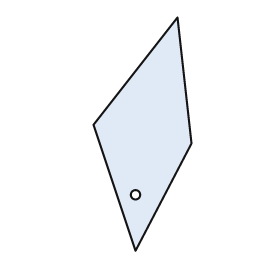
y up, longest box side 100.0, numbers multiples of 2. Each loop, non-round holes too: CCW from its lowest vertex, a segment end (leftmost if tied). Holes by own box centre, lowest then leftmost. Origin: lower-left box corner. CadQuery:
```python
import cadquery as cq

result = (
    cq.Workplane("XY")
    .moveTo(18.0, 0.0)
    .lineTo(42.0, 46.0)
    .lineTo(36.0, 100.0)
    .lineTo(0.0, 54.0)
    .close()
    .moveTo(18.0, 24.0)
    .circle(2.0)
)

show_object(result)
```